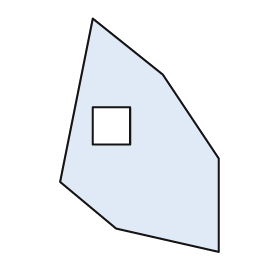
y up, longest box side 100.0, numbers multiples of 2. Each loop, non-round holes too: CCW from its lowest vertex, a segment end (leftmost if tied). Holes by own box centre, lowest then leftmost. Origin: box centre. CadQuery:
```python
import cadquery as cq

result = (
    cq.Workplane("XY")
    .moveTo(34.0, -50.0)
    .lineTo(34.0, -10.0)
    .lineTo(10.0, 26.0)
    .lineTo(-20.0, 50.0)
    .lineTo(-34.0, -20.0)
    .lineTo(-10.0, -40.0)
    .close()
    .moveTo(-20.0, -4.0)
    .lineTo(-4.0, -4.0)
    .lineTo(-4.0, 12.0)
    .lineTo(-20.0, 12.0)
    .close()
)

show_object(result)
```